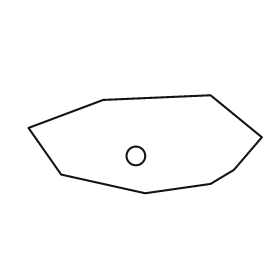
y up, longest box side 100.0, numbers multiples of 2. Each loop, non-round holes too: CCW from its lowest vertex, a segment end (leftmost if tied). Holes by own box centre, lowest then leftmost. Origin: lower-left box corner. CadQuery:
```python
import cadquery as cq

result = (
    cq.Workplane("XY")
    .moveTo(50.0, 0.0)
    .lineTo(78.0, 4.0)
    .lineTo(88.0, 10.0)
    .lineTo(100.0, 24.0)
    .lineTo(78.0, 42.0)
    .lineTo(32.0, 40.0)
    .lineTo(0.0, 28.0)
    .lineTo(14.0, 8.0)
    .close()
    .moveTo(46.0, 16.0)
    .circle(4.0)
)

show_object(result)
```